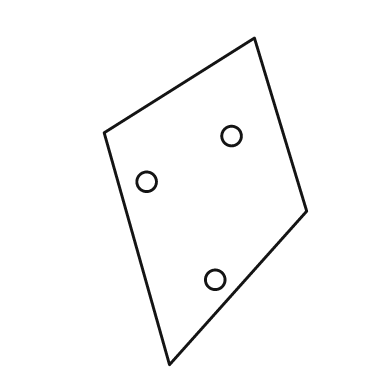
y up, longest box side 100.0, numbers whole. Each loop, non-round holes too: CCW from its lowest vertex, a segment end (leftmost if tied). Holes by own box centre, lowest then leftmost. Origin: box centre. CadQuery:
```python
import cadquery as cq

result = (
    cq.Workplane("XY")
    .moveTo(-11.0, -50.0)
    .lineTo(31.0, -3.0)
    .lineTo(15.0, 50.0)
    .lineTo(-31.0, 21.0)
    .close()
    .moveTo(3.0, -24.0)
    .circle(3.0)
    .moveTo(-18.0, 6.0)
    .circle(3.0)
    .moveTo(8.0, 20.0)
    .circle(3.0)
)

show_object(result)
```